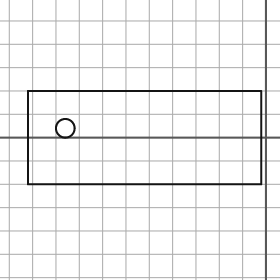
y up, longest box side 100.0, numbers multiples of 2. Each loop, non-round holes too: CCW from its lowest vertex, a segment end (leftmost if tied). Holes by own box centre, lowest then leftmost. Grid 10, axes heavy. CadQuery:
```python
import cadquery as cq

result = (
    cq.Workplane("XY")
    .moveTo(-102.0, -20.0)
    .lineTo(-2.0, -20.0)
    .lineTo(-2.0, 20.0)
    .lineTo(-102.0, 20.0)
    .close()
    .moveTo(-86.0, 4.0)
    .circle(4.0)
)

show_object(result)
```